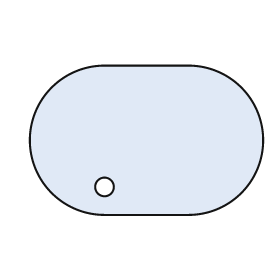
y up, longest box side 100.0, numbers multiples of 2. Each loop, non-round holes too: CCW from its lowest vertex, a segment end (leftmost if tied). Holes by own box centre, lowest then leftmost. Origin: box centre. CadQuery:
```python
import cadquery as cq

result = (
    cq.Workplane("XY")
    .moveTo(-18.0, -32.0)
    .lineTo(18.0, -32.0)
    .threePointArc((50.0, 0.0), (18.0, 32.0))
    .lineTo(-18.0, 32.0)
    .threePointArc((-50.0, 0.0), (-18.0, -32.0))
    .close()
    .moveTo(-18.0, -20.0)
    .circle(4.0)
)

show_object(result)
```